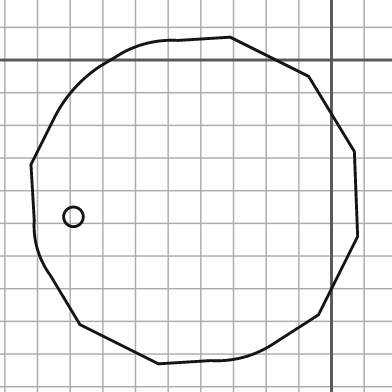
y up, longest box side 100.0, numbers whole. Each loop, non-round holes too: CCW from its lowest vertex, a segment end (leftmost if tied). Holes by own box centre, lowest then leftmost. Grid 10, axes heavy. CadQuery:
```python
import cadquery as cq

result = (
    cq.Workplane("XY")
    .moveTo(-53.0, -93.0)
    .lineTo(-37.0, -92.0)
    .threePointArc((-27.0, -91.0), (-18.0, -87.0))
    .lineTo(-4.0, -78.0)
    .lineTo(8.0, -54.0)
    .lineTo(7.0, -28.0)
    .lineTo(-7.0, -5.0)
    .lineTo(-31.0, 7.0)
    .lineTo(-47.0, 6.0)
    .threePointArc((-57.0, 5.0), (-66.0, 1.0))
    .lineTo(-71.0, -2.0)
    .threePointArc((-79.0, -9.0), (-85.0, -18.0))
    .lineTo(-92.0, -32.0)
    .lineTo(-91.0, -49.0)
    .threePointArc((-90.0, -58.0), (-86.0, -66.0))
    .lineTo(-77.0, -81.0)
    .close()
    .moveTo(-79.0, -48.0)
    .circle(3.0)
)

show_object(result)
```